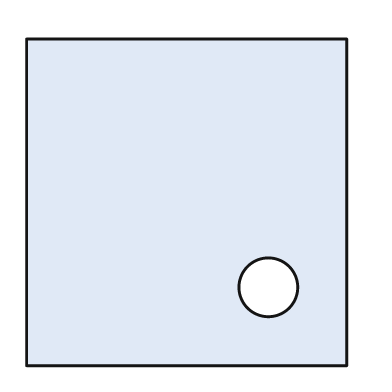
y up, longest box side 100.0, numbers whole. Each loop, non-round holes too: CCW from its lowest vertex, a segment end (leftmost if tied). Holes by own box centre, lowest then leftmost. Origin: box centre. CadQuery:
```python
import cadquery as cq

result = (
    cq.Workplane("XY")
    .moveTo(-49.0, -50.0)
    .lineTo(49.0, -50.0)
    .lineTo(49.0, 50.0)
    .lineTo(-49.0, 50.0)
    .close()
    .moveTo(25.0, -26.0)
    .circle(9.0)
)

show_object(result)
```